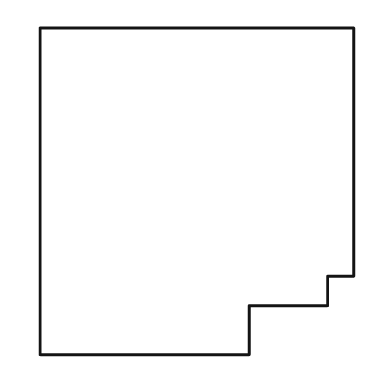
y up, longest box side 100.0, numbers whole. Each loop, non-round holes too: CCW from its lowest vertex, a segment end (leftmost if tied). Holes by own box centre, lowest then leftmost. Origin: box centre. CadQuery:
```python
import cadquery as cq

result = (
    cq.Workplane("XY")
    .moveTo(-48.0, -50.0)
    .lineTo(16.0, -50.0)
    .lineTo(16.0, -35.0)
    .lineTo(40.0, -35.0)
    .lineTo(40.0, -26.0)
    .lineTo(48.0, -26.0)
    .lineTo(48.0, 50.0)
    .lineTo(-48.0, 50.0)
    .close()
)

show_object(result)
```